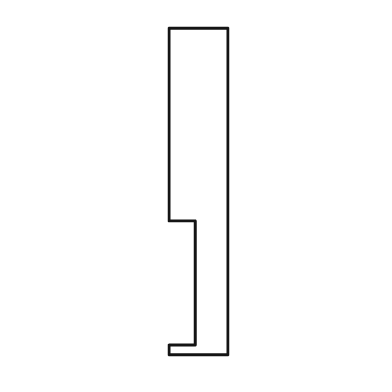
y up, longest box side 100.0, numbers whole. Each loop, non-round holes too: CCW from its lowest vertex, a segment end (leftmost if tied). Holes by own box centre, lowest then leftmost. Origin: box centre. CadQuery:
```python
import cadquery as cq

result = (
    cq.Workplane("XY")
    .moveTo(-9.0, -50.0)
    .lineTo(9.0, -50.0)
    .lineTo(9.0, 50.0)
    .lineTo(-9.0, 50.0)
    .lineTo(-9.0, -9.0)
    .lineTo(-1.0, -9.0)
    .lineTo(-1.0, -47.0)
    .lineTo(-9.0, -47.0)
    .close()
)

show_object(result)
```